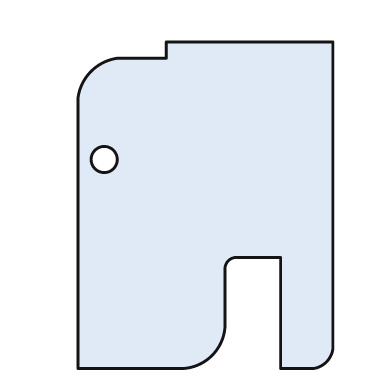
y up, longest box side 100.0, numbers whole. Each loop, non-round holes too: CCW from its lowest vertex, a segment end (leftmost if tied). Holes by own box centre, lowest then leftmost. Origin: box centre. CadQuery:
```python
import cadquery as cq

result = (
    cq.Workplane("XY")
    .moveTo(-39.0, -50.0)
    .lineTo(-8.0, -50.0)
    .threePointArc((2.0, -46.0), (6.0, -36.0))
    .lineTo(6.0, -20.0)
    .threePointArc((7.0, -17.0), (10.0, -16.0))
    .lineTo(23.0, -16.0)
    .lineTo(23.0, -50.0)
    .lineTo(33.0, -50.0)
    .threePointArc((37.0, -48.0), (39.0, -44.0))
    .lineTo(39.0, 50.0)
    .lineTo(-12.0, 50.0)
    .lineTo(-12.0, 45.0)
    .lineTo(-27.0, 45.0)
    .threePointArc((-35.0, 41.0), (-39.0, 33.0))
    .close()
    .moveTo(-31.0, 14.0)
    .circle(4.0)
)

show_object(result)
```